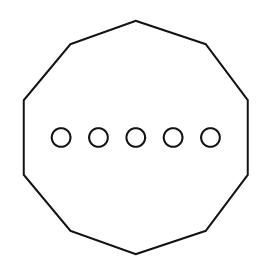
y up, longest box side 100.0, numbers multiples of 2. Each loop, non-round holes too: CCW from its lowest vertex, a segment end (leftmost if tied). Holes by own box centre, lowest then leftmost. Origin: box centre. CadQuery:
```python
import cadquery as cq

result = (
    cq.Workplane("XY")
    .moveTo(0.0, -50.0)
    .lineTo(30.0, -40.0)
    .lineTo(48.0, -16.0)
    .lineTo(48.0, 16.0)
    .lineTo(30.0, 40.0)
    .lineTo(0.0, 50.0)
    .lineTo(-28.0, 40.0)
    .lineTo(-48.0, 16.0)
    .lineTo(-48.0, -16.0)
    .lineTo(-28.0, -40.0)
    .close()
    .moveTo(-32.0, 0.0)
    .circle(4.0)
    .moveTo(-16.0, 0.0)
    .circle(4.0)
    .moveTo(0.0, 0.0)
    .circle(4.0)
    .moveTo(16.0, 0.0)
    .circle(4.0)
    .moveTo(32.0, 0.0)
    .circle(4.0)
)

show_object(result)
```